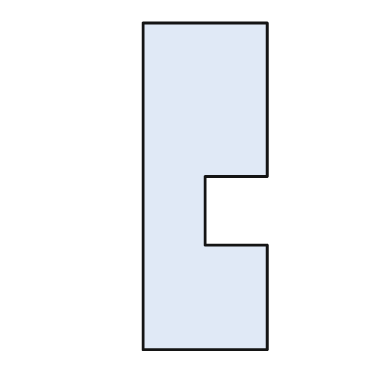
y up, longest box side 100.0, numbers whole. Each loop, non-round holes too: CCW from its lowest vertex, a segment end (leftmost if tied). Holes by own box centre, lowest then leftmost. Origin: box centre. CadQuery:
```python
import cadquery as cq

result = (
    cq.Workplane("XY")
    .moveTo(-19.0, -50.0)
    .lineTo(19.0, -50.0)
    .lineTo(19.0, -18.0)
    .lineTo(0.0, -18.0)
    .lineTo(0.0, 3.0)
    .lineTo(19.0, 3.0)
    .lineTo(19.0, 50.0)
    .lineTo(-19.0, 50.0)
    .close()
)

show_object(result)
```